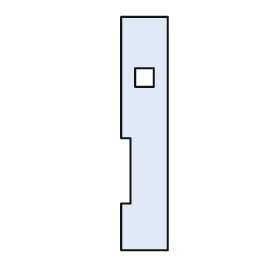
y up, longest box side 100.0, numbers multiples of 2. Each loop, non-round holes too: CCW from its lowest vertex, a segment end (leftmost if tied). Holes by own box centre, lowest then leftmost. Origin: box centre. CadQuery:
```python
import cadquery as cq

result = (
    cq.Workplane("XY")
    .moveTo(-10.0, -50.0)
    .lineTo(10.0, -50.0)
    .lineTo(10.0, 50.0)
    .lineTo(-10.0, 50.0)
    .lineTo(-10.0, -2.0)
    .lineTo(-6.0, -2.0)
    .lineTo(-6.0, -30.0)
    .lineTo(-10.0, -30.0)
    .close()
    .moveTo(-4.0, 20.0)
    .lineTo(4.0, 20.0)
    .lineTo(4.0, 28.0)
    .lineTo(-4.0, 28.0)
    .close()
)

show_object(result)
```